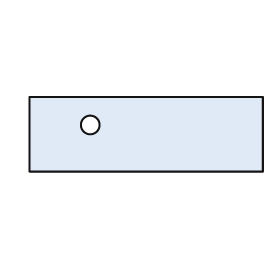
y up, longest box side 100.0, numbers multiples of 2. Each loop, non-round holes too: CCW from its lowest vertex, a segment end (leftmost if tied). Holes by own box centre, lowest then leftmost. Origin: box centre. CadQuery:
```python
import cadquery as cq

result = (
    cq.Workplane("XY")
    .moveTo(-50.0, -16.0)
    .lineTo(50.0, -16.0)
    .lineTo(50.0, 16.0)
    .lineTo(-50.0, 16.0)
    .close()
    .moveTo(-24.0, 4.0)
    .circle(4.0)
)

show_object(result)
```